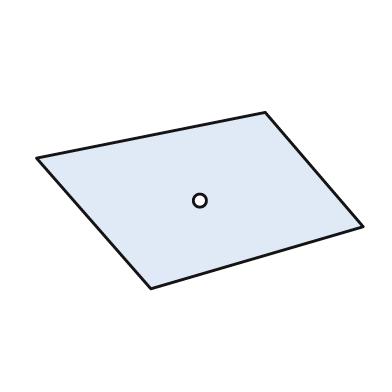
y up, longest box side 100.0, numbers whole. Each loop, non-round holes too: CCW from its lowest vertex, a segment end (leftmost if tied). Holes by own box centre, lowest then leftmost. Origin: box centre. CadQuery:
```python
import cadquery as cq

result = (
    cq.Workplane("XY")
    .moveTo(-15.0, -27.0)
    .lineTo(50.0, -8.0)
    .lineTo(20.0, 27.0)
    .lineTo(-50.0, 13.0)
    .close()
    .moveTo(0.0, 0.0)
    .circle(2.0)
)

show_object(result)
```